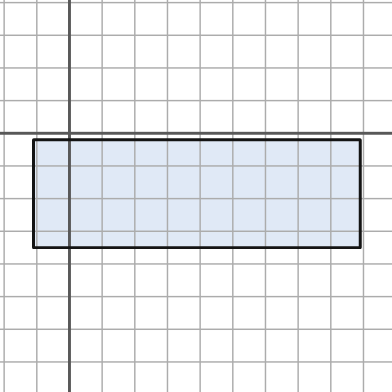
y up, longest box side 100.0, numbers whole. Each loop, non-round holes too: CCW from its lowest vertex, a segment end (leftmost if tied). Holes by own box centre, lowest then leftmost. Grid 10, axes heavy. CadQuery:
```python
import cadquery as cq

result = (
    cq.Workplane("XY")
    .moveTo(-11.0, -35.0)
    .lineTo(89.0, -35.0)
    .lineTo(89.0, -2.0)
    .lineTo(-11.0, -2.0)
    .close()
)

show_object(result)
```